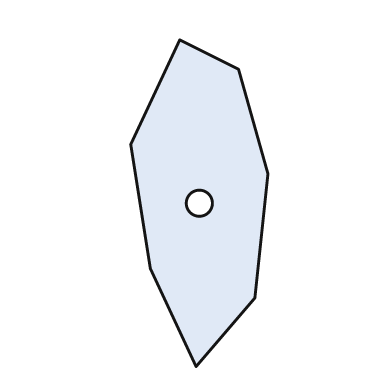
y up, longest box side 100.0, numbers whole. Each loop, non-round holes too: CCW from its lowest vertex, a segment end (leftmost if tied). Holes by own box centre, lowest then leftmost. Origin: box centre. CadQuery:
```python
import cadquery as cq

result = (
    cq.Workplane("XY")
    .moveTo(-1.0, -50.0)
    .lineTo(17.0, -29.0)
    .lineTo(21.0, 9.0)
    .lineTo(12.0, 41.0)
    .lineTo(-6.0, 50.0)
    .lineTo(-21.0, 18.0)
    .lineTo(-15.0, -20.0)
    .close()
    .moveTo(0.0, 0.0)
    .circle(4.0)
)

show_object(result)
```